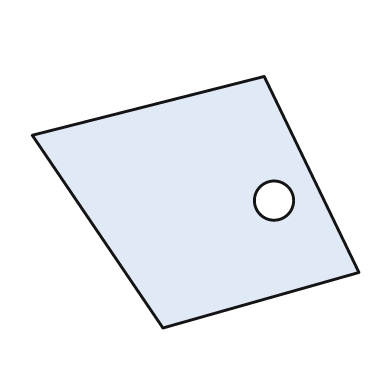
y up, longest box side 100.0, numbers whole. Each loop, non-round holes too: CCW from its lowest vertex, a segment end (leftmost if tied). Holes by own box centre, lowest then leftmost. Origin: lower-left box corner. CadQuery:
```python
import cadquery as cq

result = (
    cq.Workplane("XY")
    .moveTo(40.0, 0.0)
    .lineTo(100.0, 17.0)
    .lineTo(71.0, 77.0)
    .lineTo(0.0, 59.0)
    .close()
    .moveTo(74.0, 39.0)
    .circle(6.0)
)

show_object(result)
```